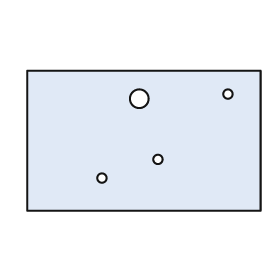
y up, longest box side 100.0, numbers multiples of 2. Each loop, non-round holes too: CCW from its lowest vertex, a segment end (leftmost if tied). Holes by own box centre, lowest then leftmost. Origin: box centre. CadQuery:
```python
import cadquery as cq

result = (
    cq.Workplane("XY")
    .moveTo(-50.0, -30.0)
    .lineTo(50.0, -30.0)
    .lineTo(50.0, 30.0)
    .lineTo(-50.0, 30.0)
    .close()
    .moveTo(-18.0, -16.0)
    .circle(2.0)
    .moveTo(6.0, -8.0)
    .circle(2.0)
    .moveTo(-2.0, 18.0)
    .circle(4.0)
    .moveTo(36.0, 20.0)
    .circle(2.0)
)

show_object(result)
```